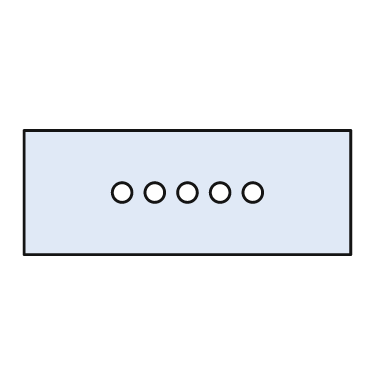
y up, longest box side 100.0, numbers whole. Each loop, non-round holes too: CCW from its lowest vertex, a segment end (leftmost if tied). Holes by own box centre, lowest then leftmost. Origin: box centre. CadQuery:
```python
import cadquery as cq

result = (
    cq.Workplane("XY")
    .moveTo(-50.0, -19.0)
    .lineTo(50.0, -19.0)
    .lineTo(50.0, 19.0)
    .lineTo(-50.0, 19.0)
    .close()
    .moveTo(-20.0, 0.0)
    .circle(3.0)
    .moveTo(-10.0, 0.0)
    .circle(3.0)
    .moveTo(0.0, 0.0)
    .circle(3.0)
    .moveTo(10.0, 0.0)
    .circle(3.0)
    .moveTo(20.0, 0.0)
    .circle(3.0)
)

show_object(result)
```